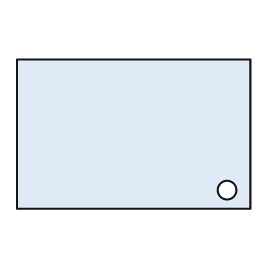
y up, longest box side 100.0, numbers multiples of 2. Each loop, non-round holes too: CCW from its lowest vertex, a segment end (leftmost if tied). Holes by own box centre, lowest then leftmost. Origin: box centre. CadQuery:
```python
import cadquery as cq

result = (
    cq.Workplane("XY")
    .moveTo(-50.0, -32.0)
    .lineTo(50.0, -32.0)
    .lineTo(50.0, 32.0)
    .lineTo(-50.0, 32.0)
    .close()
    .moveTo(40.0, -24.0)
    .circle(4.0)
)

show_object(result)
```